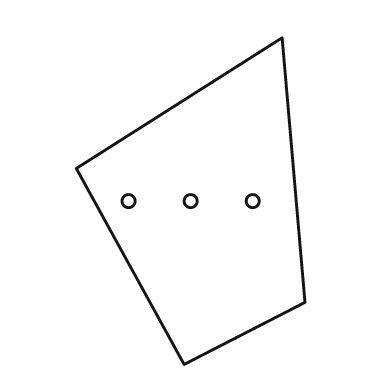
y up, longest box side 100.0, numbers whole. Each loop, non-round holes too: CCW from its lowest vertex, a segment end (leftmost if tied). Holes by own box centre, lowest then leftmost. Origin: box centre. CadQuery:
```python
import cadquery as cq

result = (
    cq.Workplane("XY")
    .moveTo(-2.0, -50.0)
    .lineTo(35.0, -31.0)
    .lineTo(28.0, 50.0)
    .lineTo(-35.0, 10.0)
    .close()
    .moveTo(-19.0, 0.0)
    .circle(2.0)
    .moveTo(0.0, 0.0)
    .circle(2.0)
    .moveTo(19.0, 0.0)
    .circle(2.0)
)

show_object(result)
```